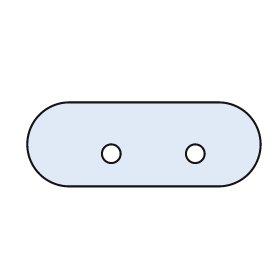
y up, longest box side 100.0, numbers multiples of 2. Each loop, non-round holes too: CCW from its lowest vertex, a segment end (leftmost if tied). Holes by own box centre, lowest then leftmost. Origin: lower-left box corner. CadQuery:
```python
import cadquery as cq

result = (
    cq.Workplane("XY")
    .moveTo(18.0, 0.0)
    .lineTo(82.0, 0.0)
    .threePointArc((100.0, 18.0), (82.0, 36.0))
    .lineTo(18.0, 36.0)
    .threePointArc((0.0, 18.0), (18.0, 0.0))
    .close()
    .moveTo(36.0, 14.0)
    .circle(4.0)
    .moveTo(72.0, 14.0)
    .circle(4.0)
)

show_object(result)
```